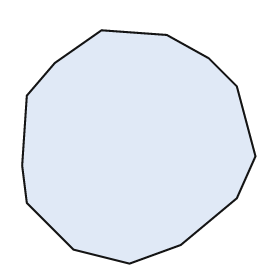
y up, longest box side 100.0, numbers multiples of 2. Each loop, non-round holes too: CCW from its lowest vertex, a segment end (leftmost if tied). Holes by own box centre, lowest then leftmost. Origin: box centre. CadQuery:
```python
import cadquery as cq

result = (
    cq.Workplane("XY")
    .moveTo(-4.0, -50.0)
    .lineTo(18.0, -42.0)
    .lineTo(42.0, -22.0)
    .lineTo(50.0, -4.0)
    .lineTo(42.0, 26.0)
    .lineTo(30.0, 38.0)
    .lineTo(12.0, 48.0)
    .lineTo(-16.0, 50.0)
    .lineTo(-36.0, 36.0)
    .lineTo(-48.0, 22.0)
    .lineTo(-50.0, -8.0)
    .lineTo(-48.0, -24.0)
    .lineTo(-28.0, -44.0)
    .close()
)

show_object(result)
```